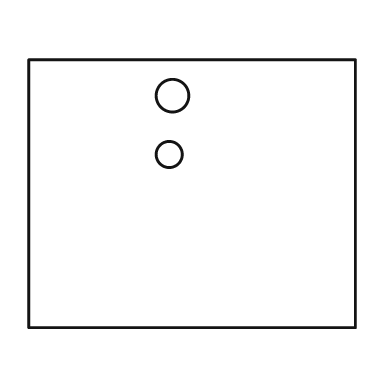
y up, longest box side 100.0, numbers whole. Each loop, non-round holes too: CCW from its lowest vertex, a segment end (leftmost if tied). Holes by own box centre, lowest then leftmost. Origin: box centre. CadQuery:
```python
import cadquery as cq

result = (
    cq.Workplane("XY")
    .moveTo(-50.0, -41.0)
    .lineTo(50.0, -41.0)
    .lineTo(50.0, 41.0)
    .lineTo(-50.0, 41.0)
    .close()
    .moveTo(-7.0, 12.0)
    .circle(4.0)
    .moveTo(-6.0, 30.0)
    .circle(5.0)
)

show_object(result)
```